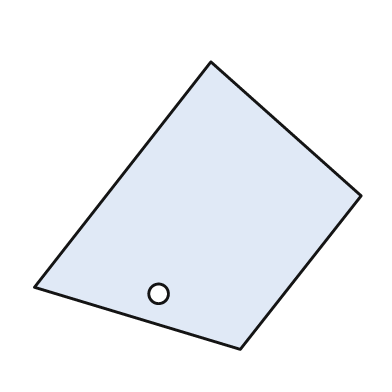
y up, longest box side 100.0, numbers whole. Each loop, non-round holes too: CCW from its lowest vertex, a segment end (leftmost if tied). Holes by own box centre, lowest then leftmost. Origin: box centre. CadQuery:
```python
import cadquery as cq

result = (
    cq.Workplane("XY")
    .moveTo(13.0, -44.0)
    .lineTo(50.0, 3.0)
    .lineTo(4.0, 44.0)
    .lineTo(-50.0, -25.0)
    .close()
    .moveTo(-12.0, -27.0)
    .circle(3.0)
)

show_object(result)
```